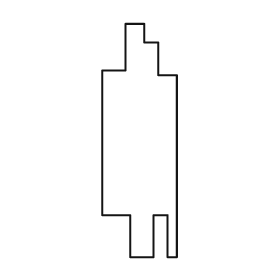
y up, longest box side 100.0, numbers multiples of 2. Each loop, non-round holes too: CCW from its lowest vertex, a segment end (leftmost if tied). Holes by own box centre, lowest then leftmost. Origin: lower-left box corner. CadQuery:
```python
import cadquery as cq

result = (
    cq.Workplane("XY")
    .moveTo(12.0, 0.0)
    .lineTo(22.0, 0.0)
    .lineTo(22.0, 18.0)
    .lineTo(28.0, 18.0)
    .lineTo(28.0, 0.0)
    .lineTo(32.0, 0.0)
    .lineTo(32.0, 78.0)
    .lineTo(24.0, 78.0)
    .lineTo(24.0, 92.0)
    .lineTo(18.0, 92.0)
    .lineTo(18.0, 100.0)
    .lineTo(10.0, 100.0)
    .lineTo(10.0, 80.0)
    .lineTo(0.0, 80.0)
    .lineTo(0.0, 18.0)
    .lineTo(12.0, 18.0)
    .close()
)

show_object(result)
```